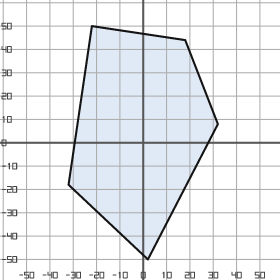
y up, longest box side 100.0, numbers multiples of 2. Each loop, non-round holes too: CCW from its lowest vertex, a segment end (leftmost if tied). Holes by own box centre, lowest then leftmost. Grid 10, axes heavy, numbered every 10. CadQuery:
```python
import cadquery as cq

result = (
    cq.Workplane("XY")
    .moveTo(2.0, -50.0)
    .lineTo(32.0, 8.0)
    .lineTo(18.0, 44.0)
    .lineTo(-22.0, 50.0)
    .lineTo(-32.0, -18.0)
    .close()
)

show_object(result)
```